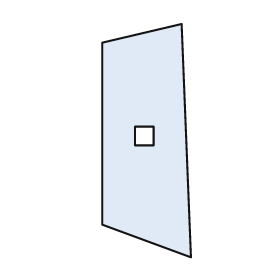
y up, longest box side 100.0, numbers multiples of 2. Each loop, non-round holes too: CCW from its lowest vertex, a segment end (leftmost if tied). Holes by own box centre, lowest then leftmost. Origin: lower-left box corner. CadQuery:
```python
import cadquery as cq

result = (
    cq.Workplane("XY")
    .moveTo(38.0, 0.0)
    .lineTo(34.0, 100.0)
    .lineTo(0.0, 92.0)
    .lineTo(0.0, 14.0)
    .close()
    .moveTo(14.0, 48.0)
    .lineTo(22.0, 48.0)
    .lineTo(22.0, 56.0)
    .lineTo(14.0, 56.0)
    .close()
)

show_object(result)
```